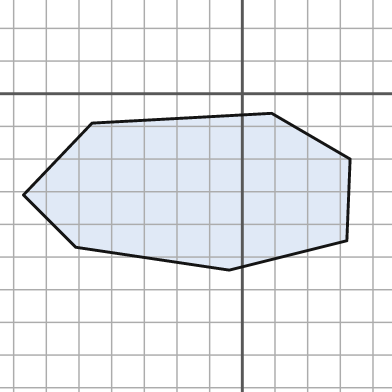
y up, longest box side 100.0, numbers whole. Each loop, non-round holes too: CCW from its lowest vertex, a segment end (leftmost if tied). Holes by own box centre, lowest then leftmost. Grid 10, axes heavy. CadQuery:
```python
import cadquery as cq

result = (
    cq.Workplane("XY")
    .moveTo(-4.0, -54.0)
    .lineTo(32.0, -45.0)
    .lineTo(33.0, -20.0)
    .lineTo(9.0, -6.0)
    .lineTo(-46.0, -9.0)
    .lineTo(-67.0, -31.0)
    .lineTo(-51.0, -47.0)
    .close()
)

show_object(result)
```